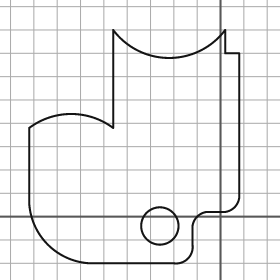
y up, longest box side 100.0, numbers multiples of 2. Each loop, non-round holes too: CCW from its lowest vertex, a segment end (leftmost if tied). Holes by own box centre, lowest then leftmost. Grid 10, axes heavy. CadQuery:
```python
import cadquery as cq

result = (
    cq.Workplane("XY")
    .moveTo(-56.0, -20.0)
    .lineTo(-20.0, -20.0)
    .threePointArc((-14.0, -18.0), (-12.0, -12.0))
    .lineTo(-12.0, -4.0)
    .threePointArc((-10.0, 0.0), (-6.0, 2.0))
    .lineTo(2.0, 2.0)
    .threePointArc((6.0, 4.0), (8.0, 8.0))
    .lineTo(8.0, 70.0)
    .lineTo(2.0, 70.0)
    .lineTo(2.0, 80.0)
    .threePointArc((-22.0, 68.0), (-46.0, 80.0))
    .lineTo(-46.0, 38.0)
    .threePointArc((-64.0, 44.0), (-82.0, 38.0))
    .lineTo(-82.0, 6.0)
    .threePointArc((-74.0, -12.0), (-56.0, -20.0))
    .close()
    .moveTo(-26.0, -4.0)
    .circle(8.0)
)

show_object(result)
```